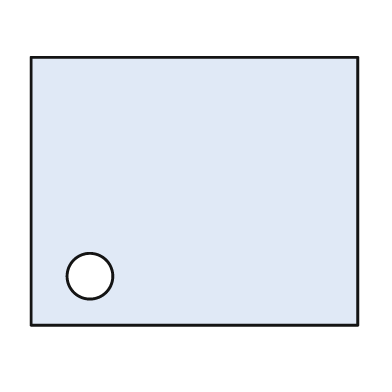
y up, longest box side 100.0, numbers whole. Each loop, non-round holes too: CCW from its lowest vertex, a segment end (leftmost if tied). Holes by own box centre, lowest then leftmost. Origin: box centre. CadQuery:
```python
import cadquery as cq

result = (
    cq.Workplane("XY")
    .moveTo(-50.0, -41.0)
    .lineTo(50.0, -41.0)
    .lineTo(50.0, 41.0)
    .lineTo(-50.0, 41.0)
    .close()
    .moveTo(-32.0, -26.0)
    .circle(7.0)
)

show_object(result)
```